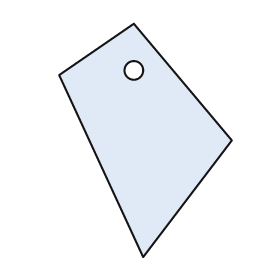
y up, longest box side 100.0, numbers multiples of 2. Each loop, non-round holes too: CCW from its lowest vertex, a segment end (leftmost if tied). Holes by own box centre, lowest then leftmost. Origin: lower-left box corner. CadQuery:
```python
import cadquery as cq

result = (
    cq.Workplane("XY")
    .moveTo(36.0, 0.0)
    .lineTo(74.0, 50.0)
    .lineTo(32.0, 100.0)
    .lineTo(0.0, 78.0)
    .close()
    .moveTo(32.0, 80.0)
    .circle(4.0)
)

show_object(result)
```